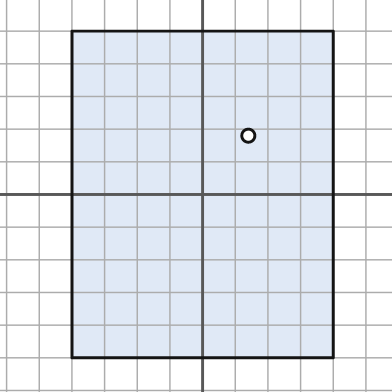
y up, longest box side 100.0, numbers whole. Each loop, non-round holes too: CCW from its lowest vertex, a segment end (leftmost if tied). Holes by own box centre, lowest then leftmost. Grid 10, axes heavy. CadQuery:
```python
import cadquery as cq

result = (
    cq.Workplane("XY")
    .moveTo(-40.0, -50.0)
    .lineTo(40.0, -50.0)
    .lineTo(40.0, 50.0)
    .lineTo(-40.0, 50.0)
    .close()
    .moveTo(14.0, 18.0)
    .circle(2.0)
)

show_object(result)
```